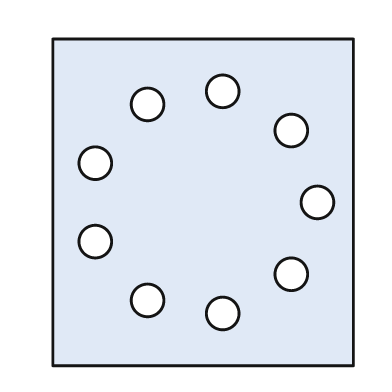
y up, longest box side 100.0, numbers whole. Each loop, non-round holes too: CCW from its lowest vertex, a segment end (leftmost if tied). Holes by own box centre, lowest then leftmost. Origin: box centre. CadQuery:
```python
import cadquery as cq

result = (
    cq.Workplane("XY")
    .moveTo(-46.0, -50.0)
    .lineTo(46.0, -50.0)
    .lineTo(46.0, 50.0)
    .lineTo(-46.0, 50.0)
    .close()
    .moveTo(6.0, -34.0)
    .circle(5.0)
    .moveTo(-17.0, -30.0)
    .circle(5.0)
    .moveTo(27.0, -22.0)
    .circle(5.0)
    .moveTo(-33.0, -12.0)
    .circle(5.0)
    .moveTo(35.0, 0.0)
    .circle(5.0)
    .moveTo(-33.0, 12.0)
    .circle(5.0)
    .moveTo(27.0, 22.0)
    .circle(5.0)
    .moveTo(-17.0, 30.0)
    .circle(5.0)
    .moveTo(6.0, 34.0)
    .circle(5.0)
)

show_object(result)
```